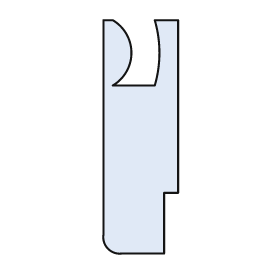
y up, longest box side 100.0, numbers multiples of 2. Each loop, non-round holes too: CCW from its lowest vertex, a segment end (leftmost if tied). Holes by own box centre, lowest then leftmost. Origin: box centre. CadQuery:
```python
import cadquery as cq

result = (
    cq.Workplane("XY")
    .moveTo(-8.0, -50.0)
    .lineTo(10.0, -50.0)
    .lineTo(10.0, -24.0)
    .lineTo(16.0, -24.0)
    .lineTo(16.0, 50.0)
    .lineTo(6.0, 50.0)
    .threePointArc((8.0, 36.0), (6.0, 22.0))
    .lineTo(-12.0, 22.0)
    .threePointArc((-4.0, 36.0), (-12.0, 50.0))
    .lineTo(-16.0, 50.0)
    .lineTo(-16.0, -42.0)
    .threePointArc((-14.0, -48.0), (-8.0, -50.0))
    .close()
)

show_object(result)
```